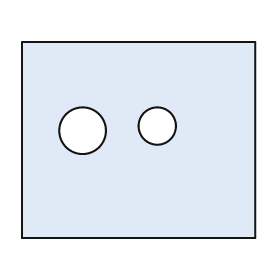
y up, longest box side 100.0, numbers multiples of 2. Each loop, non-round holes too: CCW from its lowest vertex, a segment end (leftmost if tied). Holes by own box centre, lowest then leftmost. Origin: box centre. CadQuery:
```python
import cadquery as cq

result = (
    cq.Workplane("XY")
    .moveTo(-50.0, -42.0)
    .lineTo(50.0, -42.0)
    .lineTo(50.0, 42.0)
    .lineTo(-50.0, 42.0)
    .close()
    .moveTo(-24.0, 4.0)
    .circle(10.0)
    .moveTo(8.0, 6.0)
    .circle(8.0)
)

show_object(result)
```